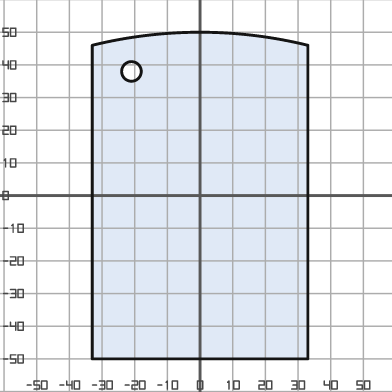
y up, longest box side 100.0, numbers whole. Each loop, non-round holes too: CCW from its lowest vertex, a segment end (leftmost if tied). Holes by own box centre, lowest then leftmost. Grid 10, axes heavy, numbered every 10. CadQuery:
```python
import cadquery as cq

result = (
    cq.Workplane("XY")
    .moveTo(-33.0, -50.0)
    .lineTo(33.0, -50.0)
    .lineTo(33.0, 46.0)
    .threePointArc((0.0, 50.0), (-33.0, 46.0))
    .close()
    .moveTo(-21.0, 38.0)
    .circle(3.0)
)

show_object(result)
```